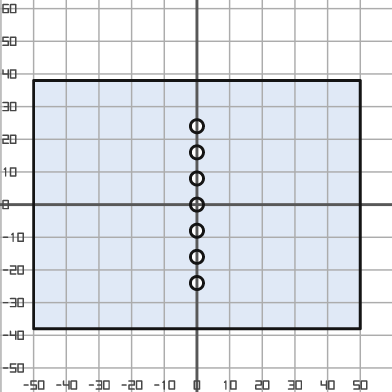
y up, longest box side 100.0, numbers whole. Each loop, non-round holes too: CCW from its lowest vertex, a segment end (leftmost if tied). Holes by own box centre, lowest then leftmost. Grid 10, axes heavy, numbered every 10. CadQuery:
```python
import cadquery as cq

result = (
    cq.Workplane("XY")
    .moveTo(-50.0, -38.0)
    .lineTo(50.0, -38.0)
    .lineTo(50.0, 38.0)
    .lineTo(-50.0, 38.0)
    .close()
    .moveTo(0.0, -24.0)
    .circle(2.0)
    .moveTo(0.0, -16.0)
    .circle(2.0)
    .moveTo(0.0, -8.0)
    .circle(2.0)
    .moveTo(0.0, 0.0)
    .circle(2.0)
    .moveTo(0.0, 8.0)
    .circle(2.0)
    .moveTo(0.0, 16.0)
    .circle(2.0)
    .moveTo(0.0, 24.0)
    .circle(2.0)
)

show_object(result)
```